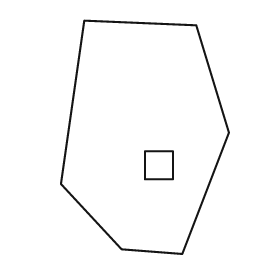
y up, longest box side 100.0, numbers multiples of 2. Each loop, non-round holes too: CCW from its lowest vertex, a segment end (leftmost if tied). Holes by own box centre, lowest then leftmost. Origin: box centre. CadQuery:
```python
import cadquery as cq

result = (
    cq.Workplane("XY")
    .moveTo(16.0, -50.0)
    .lineTo(36.0, 2.0)
    .lineTo(22.0, 48.0)
    .lineTo(-26.0, 50.0)
    .lineTo(-36.0, -20.0)
    .lineTo(-10.0, -48.0)
    .close()
    .moveTo(0.0, -18.0)
    .lineTo(12.0, -18.0)
    .lineTo(12.0, -6.0)
    .lineTo(0.0, -6.0)
    .close()
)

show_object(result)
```